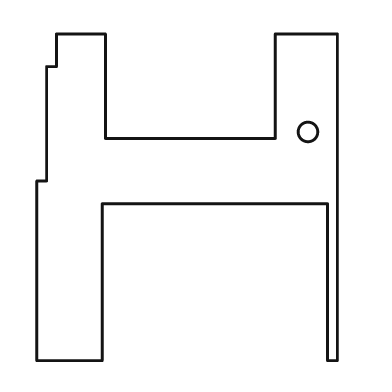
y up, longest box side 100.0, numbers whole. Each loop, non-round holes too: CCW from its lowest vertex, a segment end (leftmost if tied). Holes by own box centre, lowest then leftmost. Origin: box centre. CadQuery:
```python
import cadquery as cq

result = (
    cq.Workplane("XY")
    .moveTo(-46.0, -50.0)
    .lineTo(-26.0, -50.0)
    .lineTo(-26.0, -2.0)
    .lineTo(43.0, -2.0)
    .lineTo(43.0, -50.0)
    .lineTo(46.0, -50.0)
    .lineTo(46.0, 50.0)
    .lineTo(27.0, 50.0)
    .lineTo(27.0, 18.0)
    .lineTo(-25.0, 18.0)
    .lineTo(-25.0, 50.0)
    .lineTo(-40.0, 50.0)
    .lineTo(-40.0, 40.0)
    .lineTo(-43.0, 40.0)
    .lineTo(-43.0, 5.0)
    .lineTo(-46.0, 5.0)
    .close()
    .moveTo(37.0, 20.0)
    .circle(3.0)
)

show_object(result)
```